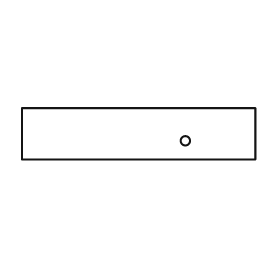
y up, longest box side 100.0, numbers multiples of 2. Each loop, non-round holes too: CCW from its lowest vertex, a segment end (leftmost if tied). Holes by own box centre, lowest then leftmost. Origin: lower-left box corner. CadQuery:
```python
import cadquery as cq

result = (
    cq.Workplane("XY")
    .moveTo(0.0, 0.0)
    .lineTo(100.0, 0.0)
    .lineTo(100.0, 22.0)
    .lineTo(0.0, 22.0)
    .close()
    .moveTo(70.0, 8.0)
    .circle(2.0)
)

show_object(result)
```